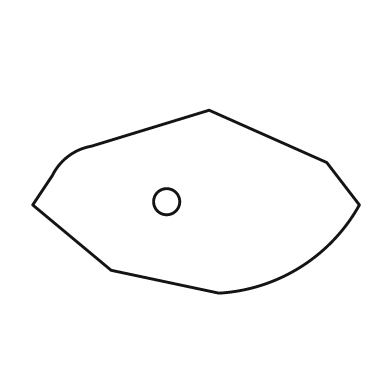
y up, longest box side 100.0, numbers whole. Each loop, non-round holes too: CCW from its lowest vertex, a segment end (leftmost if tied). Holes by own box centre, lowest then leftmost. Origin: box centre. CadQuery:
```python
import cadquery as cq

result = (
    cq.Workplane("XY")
    .moveTo(7.0, -28.0)
    .threePointArc((32.0, -20.0), (50.0, -1.0))
    .lineTo(40.0, 12.0)
    .lineTo(4.0, 28.0)
    .lineTo(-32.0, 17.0)
    .threePointArc((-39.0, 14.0), (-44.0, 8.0))
    .lineTo(-50.0, -1.0)
    .lineTo(-26.0, -21.0)
    .close()
    .moveTo(-9.0, 0.0)
    .circle(4.0)
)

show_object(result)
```